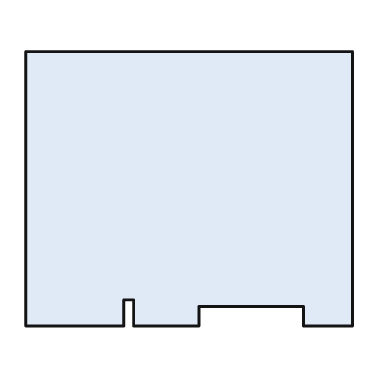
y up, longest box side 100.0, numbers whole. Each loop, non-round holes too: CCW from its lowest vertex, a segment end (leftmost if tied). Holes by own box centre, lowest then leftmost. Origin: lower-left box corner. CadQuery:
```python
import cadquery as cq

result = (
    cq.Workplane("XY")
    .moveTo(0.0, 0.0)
    .lineTo(30.0, 0.0)
    .lineTo(30.0, 8.0)
    .lineTo(33.0, 8.0)
    .lineTo(33.0, 0.0)
    .lineTo(53.0, 0.0)
    .lineTo(53.0, 6.0)
    .lineTo(85.0, 6.0)
    .lineTo(85.0, 0.0)
    .lineTo(100.0, 0.0)
    .lineTo(100.0, 84.0)
    .lineTo(0.0, 84.0)
    .close()
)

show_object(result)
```